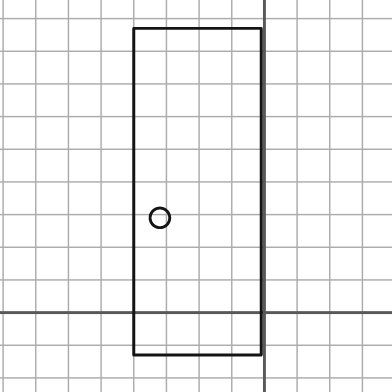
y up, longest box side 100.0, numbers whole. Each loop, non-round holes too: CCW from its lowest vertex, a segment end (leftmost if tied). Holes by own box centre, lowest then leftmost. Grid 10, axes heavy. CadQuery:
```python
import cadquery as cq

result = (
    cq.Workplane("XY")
    .moveTo(-40.0, -13.0)
    .lineTo(-1.0, -13.0)
    .lineTo(-1.0, 87.0)
    .lineTo(-40.0, 87.0)
    .close()
    .moveTo(-32.0, 29.0)
    .circle(3.0)
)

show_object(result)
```